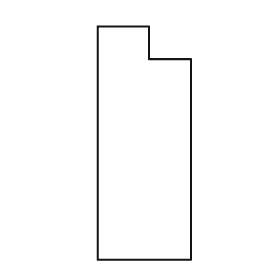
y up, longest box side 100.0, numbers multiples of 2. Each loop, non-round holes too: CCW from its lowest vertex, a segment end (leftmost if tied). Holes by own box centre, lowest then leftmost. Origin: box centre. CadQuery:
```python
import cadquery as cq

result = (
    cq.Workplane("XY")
    .moveTo(-20.0, -50.0)
    .lineTo(20.0, -50.0)
    .lineTo(20.0, 36.0)
    .lineTo(2.0, 36.0)
    .lineTo(2.0, 50.0)
    .lineTo(-20.0, 50.0)
    .close()
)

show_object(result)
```